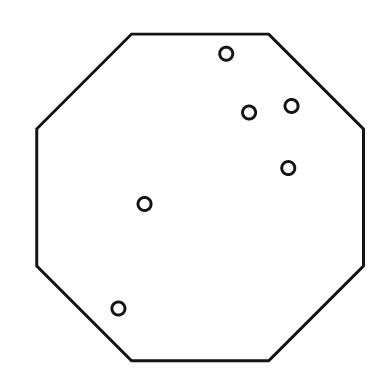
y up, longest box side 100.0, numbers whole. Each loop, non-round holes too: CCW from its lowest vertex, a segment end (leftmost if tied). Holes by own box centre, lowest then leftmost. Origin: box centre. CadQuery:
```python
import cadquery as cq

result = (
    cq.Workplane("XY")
    .moveTo(-21.0, -50.0)
    .lineTo(21.0, -50.0)
    .lineTo(50.0, -21.0)
    .lineTo(50.0, 21.0)
    .lineTo(21.0, 50.0)
    .lineTo(-21.0, 50.0)
    .lineTo(-50.0, 21.0)
    .lineTo(-50.0, -21.0)
    .close()
    .moveTo(-25.0, -34.0)
    .circle(2.0)
    .moveTo(-17.0, -2.0)
    .circle(2.0)
    .moveTo(27.0, 9.0)
    .circle(2.0)
    .moveTo(15.0, 26.0)
    .circle(2.0)
    .moveTo(28.0, 28.0)
    .circle(2.0)
    .moveTo(8.0, 44.0)
    .circle(2.0)
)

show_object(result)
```